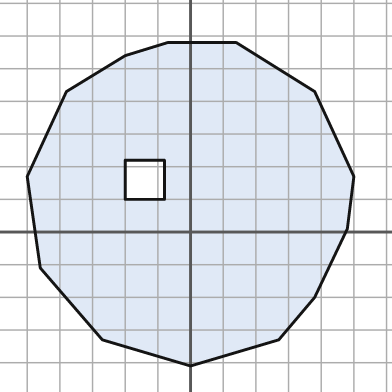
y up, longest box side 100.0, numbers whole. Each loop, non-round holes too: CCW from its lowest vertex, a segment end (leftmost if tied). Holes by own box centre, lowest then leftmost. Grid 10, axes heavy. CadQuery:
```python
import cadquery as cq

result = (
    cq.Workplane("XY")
    .moveTo(0.0, -41.0)
    .lineTo(27.0, -33.0)
    .lineTo(38.0, -20.0)
    .lineTo(48.0, 1.0)
    .lineTo(50.0, 17.0)
    .lineTo(38.0, 43.0)
    .lineTo(14.0, 58.0)
    .lineTo(-7.0, 58.0)
    .lineTo(-20.0, 54.0)
    .lineTo(-38.0, 43.0)
    .lineTo(-50.0, 17.0)
    .lineTo(-46.0, -11.0)
    .lineTo(-27.0, -33.0)
    .close()
    .moveTo(-20.0, 10.0)
    .lineTo(-8.0, 10.0)
    .lineTo(-8.0, 22.0)
    .lineTo(-20.0, 22.0)
    .close()
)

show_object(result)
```